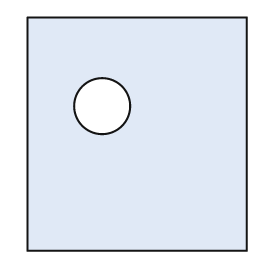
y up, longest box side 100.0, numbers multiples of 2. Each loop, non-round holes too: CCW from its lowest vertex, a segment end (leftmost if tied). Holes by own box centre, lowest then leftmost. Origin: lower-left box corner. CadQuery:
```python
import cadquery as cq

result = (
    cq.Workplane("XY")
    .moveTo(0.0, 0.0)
    .lineTo(94.0, 0.0)
    .lineTo(94.0, 100.0)
    .lineTo(0.0, 100.0)
    .close()
    .moveTo(32.0, 62.0)
    .circle(12.0)
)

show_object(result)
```